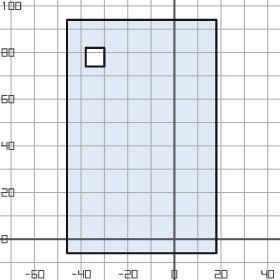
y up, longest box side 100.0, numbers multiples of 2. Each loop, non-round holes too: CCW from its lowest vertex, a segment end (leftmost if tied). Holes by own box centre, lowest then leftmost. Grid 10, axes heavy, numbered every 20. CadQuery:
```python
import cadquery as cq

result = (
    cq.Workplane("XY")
    .moveTo(-46.0, -6.0)
    .lineTo(18.0, -6.0)
    .lineTo(18.0, 94.0)
    .lineTo(-46.0, 94.0)
    .close()
    .moveTo(-38.0, 74.0)
    .lineTo(-30.0, 74.0)
    .lineTo(-30.0, 82.0)
    .lineTo(-38.0, 82.0)
    .close()
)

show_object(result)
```